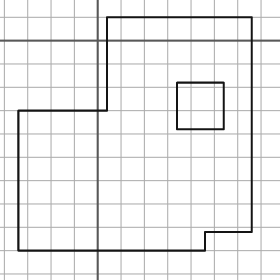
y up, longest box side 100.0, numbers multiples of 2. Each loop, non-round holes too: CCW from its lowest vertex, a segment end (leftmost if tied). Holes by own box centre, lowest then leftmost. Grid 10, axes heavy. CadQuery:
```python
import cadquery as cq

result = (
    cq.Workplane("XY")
    .moveTo(-34.0, -90.0)
    .lineTo(46.0, -90.0)
    .lineTo(46.0, -82.0)
    .lineTo(66.0, -82.0)
    .lineTo(66.0, 10.0)
    .lineTo(4.0, 10.0)
    .lineTo(4.0, -30.0)
    .lineTo(-34.0, -30.0)
    .close()
    .moveTo(34.0, -38.0)
    .lineTo(54.0, -38.0)
    .lineTo(54.0, -18.0)
    .lineTo(34.0, -18.0)
    .close()
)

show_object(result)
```